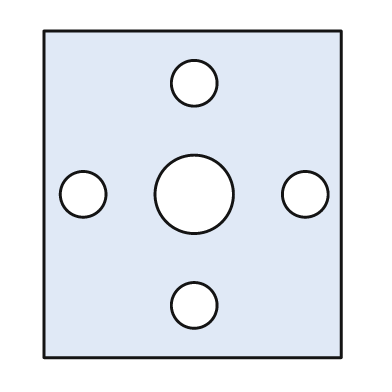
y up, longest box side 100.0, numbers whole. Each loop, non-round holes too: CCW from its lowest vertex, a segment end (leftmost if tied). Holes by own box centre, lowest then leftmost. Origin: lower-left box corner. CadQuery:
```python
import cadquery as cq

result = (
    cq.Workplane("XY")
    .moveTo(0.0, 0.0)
    .lineTo(91.0, 0.0)
    .lineTo(91.0, 100.0)
    .lineTo(0.0, 100.0)
    .close()
    .moveTo(46.0, 16.0)
    .circle(7.0)
    .moveTo(12.0, 50.0)
    .circle(7.0)
    .moveTo(46.0, 50.0)
    .circle(12.0)
    .moveTo(80.0, 50.0)
    .circle(7.0)
    .moveTo(46.0, 84.0)
    .circle(7.0)
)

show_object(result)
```